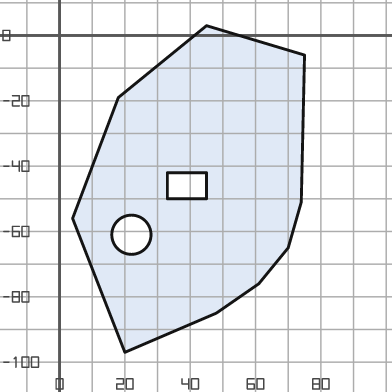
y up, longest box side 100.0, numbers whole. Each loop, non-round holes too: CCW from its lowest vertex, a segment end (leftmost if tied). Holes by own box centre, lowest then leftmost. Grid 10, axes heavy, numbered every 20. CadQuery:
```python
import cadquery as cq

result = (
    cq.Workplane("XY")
    .moveTo(20.0, -97.0)
    .lineTo(48.0, -85.0)
    .lineTo(61.0, -76.0)
    .lineTo(70.0, -65.0)
    .lineTo(74.0, -51.0)
    .lineTo(75.0, -6.0)
    .lineTo(45.0, 3.0)
    .lineTo(18.0, -19.0)
    .lineTo(4.0, -56.0)
    .close()
    .moveTo(22.0, -61.0)
    .circle(6.0)
    .moveTo(33.0, -50.0)
    .lineTo(45.0, -50.0)
    .lineTo(45.0, -42.0)
    .lineTo(33.0, -42.0)
    .close()
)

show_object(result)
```